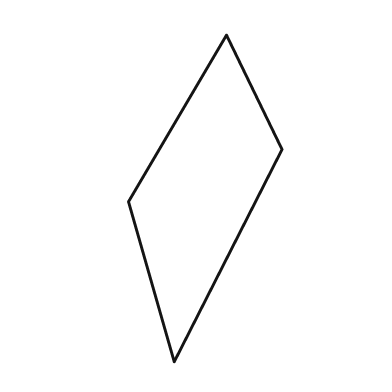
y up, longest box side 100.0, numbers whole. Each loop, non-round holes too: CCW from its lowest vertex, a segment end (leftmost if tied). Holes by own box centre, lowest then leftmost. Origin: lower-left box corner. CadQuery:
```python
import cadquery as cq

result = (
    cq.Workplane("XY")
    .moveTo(14.0, 0.0)
    .lineTo(47.0, 65.0)
    .lineTo(30.0, 100.0)
    .lineTo(0.0, 49.0)
    .close()
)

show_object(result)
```